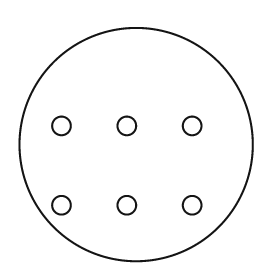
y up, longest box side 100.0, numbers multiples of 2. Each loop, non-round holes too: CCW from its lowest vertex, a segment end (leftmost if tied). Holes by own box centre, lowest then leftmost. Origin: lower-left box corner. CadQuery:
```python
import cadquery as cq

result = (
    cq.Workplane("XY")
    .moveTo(50.0, 50.0)
    .circle(50.0)
    .moveTo(18.0, 24.0)
    .circle(4.0)
    .moveTo(46.0, 24.0)
    .circle(4.0)
    .moveTo(74.0, 24.0)
    .circle(4.0)
    .moveTo(18.0, 58.0)
    .circle(4.0)
    .moveTo(46.0, 58.0)
    .circle(4.0)
    .moveTo(74.0, 58.0)
    .circle(4.0)
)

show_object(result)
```